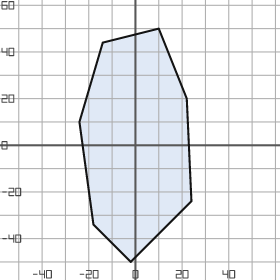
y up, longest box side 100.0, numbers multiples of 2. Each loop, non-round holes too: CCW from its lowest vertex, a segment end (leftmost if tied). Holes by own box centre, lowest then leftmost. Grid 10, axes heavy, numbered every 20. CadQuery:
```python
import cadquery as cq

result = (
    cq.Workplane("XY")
    .moveTo(-2.0, -50.0)
    .lineTo(24.0, -24.0)
    .lineTo(22.0, 20.0)
    .lineTo(10.0, 50.0)
    .lineTo(-14.0, 44.0)
    .lineTo(-24.0, 10.0)
    .lineTo(-18.0, -34.0)
    .close()
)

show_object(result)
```